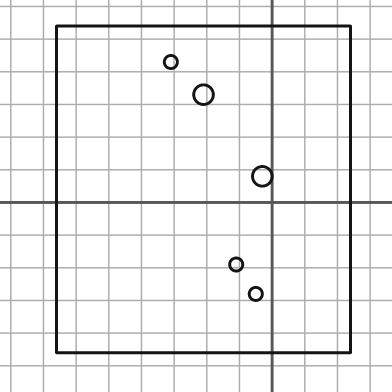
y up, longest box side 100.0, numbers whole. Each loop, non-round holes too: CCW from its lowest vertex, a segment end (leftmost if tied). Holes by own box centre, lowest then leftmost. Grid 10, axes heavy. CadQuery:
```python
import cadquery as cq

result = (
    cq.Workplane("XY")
    .moveTo(-66.0, -46.0)
    .lineTo(24.0, -46.0)
    .lineTo(24.0, 54.0)
    .lineTo(-66.0, 54.0)
    .close()
    .moveTo(-5.0, -28.0)
    .circle(2.0)
    .moveTo(-11.0, -19.0)
    .circle(2.0)
    .moveTo(-3.0, 8.0)
    .circle(3.0)
    .moveTo(-21.0, 33.0)
    .circle(3.0)
    .moveTo(-31.0, 43.0)
    .circle(2.0)
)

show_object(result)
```